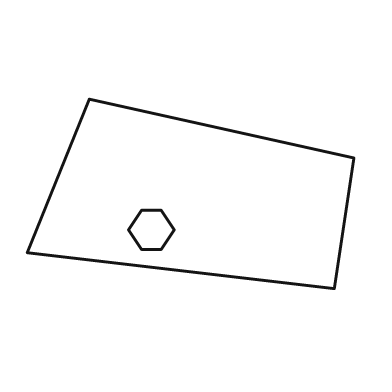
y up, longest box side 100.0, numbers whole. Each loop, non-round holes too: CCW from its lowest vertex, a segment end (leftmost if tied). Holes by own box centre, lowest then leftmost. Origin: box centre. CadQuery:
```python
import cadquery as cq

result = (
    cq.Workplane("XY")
    .moveTo(44.0, -29.0)
    .lineTo(50.0, 11.0)
    .lineTo(-31.0, 29.0)
    .lineTo(-50.0, -18.0)
    .close()
    .moveTo(-15.0, -17.0)
    .lineTo(-9.0, -17.0)
    .lineTo(-5.0, -11.0)
    .lineTo(-9.0, -5.0)
    .lineTo(-15.0, -5.0)
    .lineTo(-19.0, -11.0)
    .close()
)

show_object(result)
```